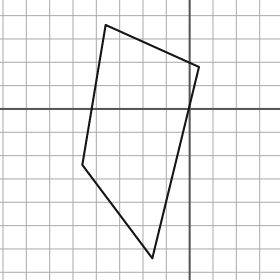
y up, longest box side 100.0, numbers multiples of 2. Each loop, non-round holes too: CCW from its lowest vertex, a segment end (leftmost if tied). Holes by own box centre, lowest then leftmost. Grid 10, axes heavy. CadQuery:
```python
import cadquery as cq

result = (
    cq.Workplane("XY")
    .moveTo(-16.0, -64.0)
    .lineTo(4.0, 18.0)
    .lineTo(-36.0, 36.0)
    .lineTo(-46.0, -24.0)
    .close()
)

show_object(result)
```